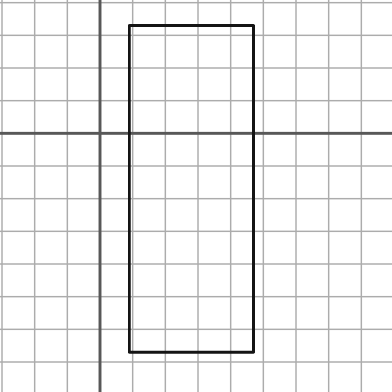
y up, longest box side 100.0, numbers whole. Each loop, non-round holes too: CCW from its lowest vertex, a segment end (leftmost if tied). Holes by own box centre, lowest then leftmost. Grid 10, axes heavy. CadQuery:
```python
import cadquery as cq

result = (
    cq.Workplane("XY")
    .moveTo(9.0, -67.0)
    .lineTo(47.0, -67.0)
    .lineTo(47.0, 33.0)
    .lineTo(9.0, 33.0)
    .close()
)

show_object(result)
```